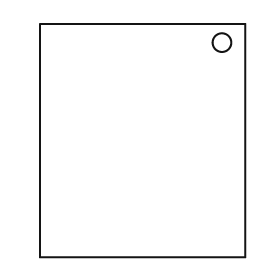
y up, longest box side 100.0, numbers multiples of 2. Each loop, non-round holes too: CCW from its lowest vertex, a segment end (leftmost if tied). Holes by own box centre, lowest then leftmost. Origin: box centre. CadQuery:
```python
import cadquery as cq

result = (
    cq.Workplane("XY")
    .moveTo(-44.0, -50.0)
    .lineTo(44.0, -50.0)
    .lineTo(44.0, 50.0)
    .lineTo(-44.0, 50.0)
    .close()
    .moveTo(34.0, 42.0)
    .circle(4.0)
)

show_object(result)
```